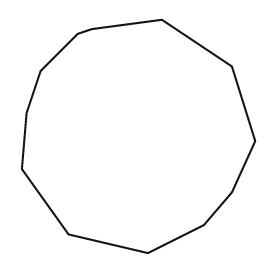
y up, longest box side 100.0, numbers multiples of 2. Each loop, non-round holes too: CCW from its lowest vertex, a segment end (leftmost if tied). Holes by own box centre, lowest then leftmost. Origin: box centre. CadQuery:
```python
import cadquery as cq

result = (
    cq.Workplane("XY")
    .moveTo(4.0, -50.0)
    .lineTo(28.0, -38.0)
    .lineTo(40.0, -24.0)
    .lineTo(50.0, -2.0)
    .lineTo(40.0, 30.0)
    .lineTo(10.0, 50.0)
    .lineTo(-20.0, 46.0)
    .lineTo(-26.0, 44.0)
    .lineTo(-42.0, 28.0)
    .lineTo(-48.0, 10.0)
    .lineTo(-50.0, -14.0)
    .lineTo(-30.0, -42.0)
    .close()
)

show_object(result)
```